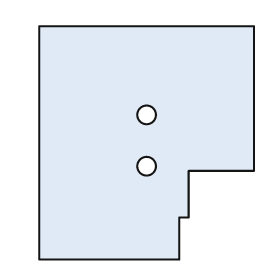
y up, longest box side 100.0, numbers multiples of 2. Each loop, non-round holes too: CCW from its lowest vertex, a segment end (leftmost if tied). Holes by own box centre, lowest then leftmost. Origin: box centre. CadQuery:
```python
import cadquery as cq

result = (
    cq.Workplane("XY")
    .moveTo(-46.0, -50.0)
    .lineTo(14.0, -50.0)
    .lineTo(14.0, -32.0)
    .lineTo(18.0, -32.0)
    .lineTo(18.0, -12.0)
    .lineTo(46.0, -12.0)
    .lineTo(46.0, 50.0)
    .lineTo(-46.0, 50.0)
    .close()
    .moveTo(0.0, -10.0)
    .circle(4.0)
    .moveTo(0.0, 12.0)
    .circle(4.0)
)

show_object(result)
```